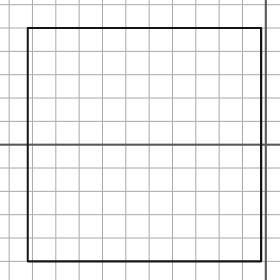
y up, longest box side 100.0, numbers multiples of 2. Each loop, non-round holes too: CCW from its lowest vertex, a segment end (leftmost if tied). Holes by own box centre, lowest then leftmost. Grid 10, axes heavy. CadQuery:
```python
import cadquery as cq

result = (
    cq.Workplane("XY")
    .moveTo(-102.0, -50.0)
    .lineTo(-2.0, -50.0)
    .lineTo(-2.0, 50.0)
    .lineTo(-102.0, 50.0)
    .close()
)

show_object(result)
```